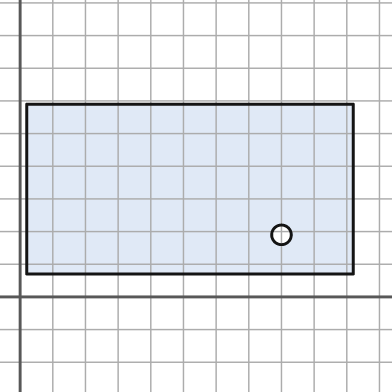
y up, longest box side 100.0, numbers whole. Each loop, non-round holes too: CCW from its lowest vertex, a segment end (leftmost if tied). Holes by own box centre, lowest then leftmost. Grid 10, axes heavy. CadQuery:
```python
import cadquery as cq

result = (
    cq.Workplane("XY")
    .moveTo(2.0, 7.0)
    .lineTo(102.0, 7.0)
    .lineTo(102.0, 59.0)
    .lineTo(2.0, 59.0)
    .close()
    .moveTo(80.0, 19.0)
    .circle(3.0)
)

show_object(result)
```